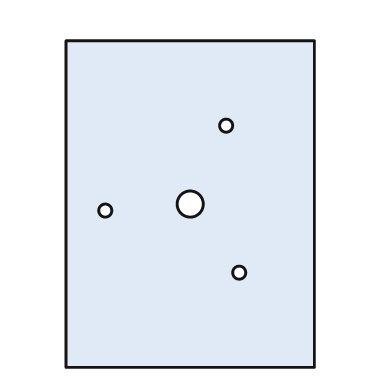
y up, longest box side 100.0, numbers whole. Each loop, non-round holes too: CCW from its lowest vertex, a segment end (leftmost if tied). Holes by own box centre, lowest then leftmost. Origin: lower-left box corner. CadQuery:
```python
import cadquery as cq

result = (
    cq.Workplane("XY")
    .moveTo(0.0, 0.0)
    .lineTo(76.0, 0.0)
    .lineTo(76.0, 100.0)
    .lineTo(0.0, 100.0)
    .close()
    .moveTo(53.0, 29.0)
    .circle(2.0)
    .moveTo(12.0, 48.0)
    .circle(2.0)
    .moveTo(38.0, 50.0)
    .circle(4.0)
    .moveTo(49.0, 74.0)
    .circle(2.0)
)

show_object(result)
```